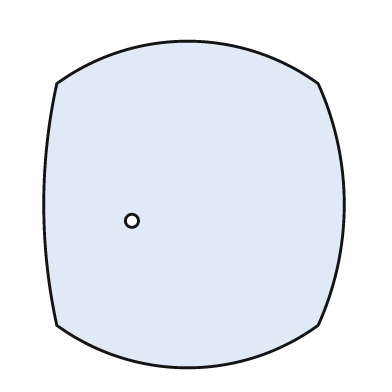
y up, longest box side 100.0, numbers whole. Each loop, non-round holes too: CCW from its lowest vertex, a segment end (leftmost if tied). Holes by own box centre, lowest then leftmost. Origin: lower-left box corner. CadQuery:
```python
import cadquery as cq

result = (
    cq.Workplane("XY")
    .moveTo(4.0, 13.0)
    .threePointArc((44.0, 0.0), (84.0, 13.0))
    .threePointArc((92.0, 50.0), (84.0, 87.0))
    .threePointArc((44.0, 100.0), (4.0, 87.0))
    .threePointArc((0.0, 50.0), (4.0, 13.0))
    .close()
    .moveTo(27.0, 45.0)
    .circle(2.0)
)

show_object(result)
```